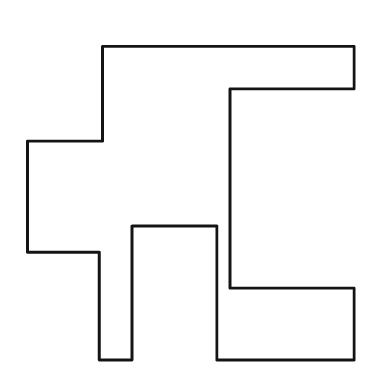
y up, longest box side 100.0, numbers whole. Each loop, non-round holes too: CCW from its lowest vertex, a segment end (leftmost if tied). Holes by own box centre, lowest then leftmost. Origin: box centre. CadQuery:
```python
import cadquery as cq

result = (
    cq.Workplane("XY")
    .moveTo(-28.0, -48.0)
    .lineTo(-18.0, -48.0)
    .lineTo(-18.0, -7.0)
    .lineTo(8.0, -7.0)
    .lineTo(8.0, -48.0)
    .lineTo(50.0, -48.0)
    .lineTo(50.0, -26.0)
    .lineTo(12.0, -26.0)
    .lineTo(12.0, 35.0)
    .lineTo(50.0, 35.0)
    .lineTo(50.0, 48.0)
    .lineTo(-27.0, 48.0)
    .lineTo(-27.0, 19.0)
    .lineTo(-50.0, 19.0)
    .lineTo(-50.0, -15.0)
    .lineTo(-28.0, -15.0)
    .close()
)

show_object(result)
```